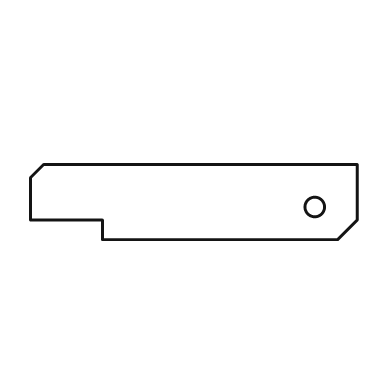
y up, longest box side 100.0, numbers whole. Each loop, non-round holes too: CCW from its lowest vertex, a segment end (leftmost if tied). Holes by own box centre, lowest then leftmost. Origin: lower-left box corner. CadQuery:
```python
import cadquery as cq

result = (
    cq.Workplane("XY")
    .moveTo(22.0, 0.0)
    .lineTo(94.0, 0.0)
    .lineTo(100.0, 6.0)
    .lineTo(100.0, 23.0)
    .lineTo(4.0, 23.0)
    .lineTo(0.0, 19.0)
    .lineTo(0.0, 6.0)
    .lineTo(22.0, 6.0)
    .close()
    .moveTo(87.0, 10.0)
    .circle(3.0)
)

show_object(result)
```